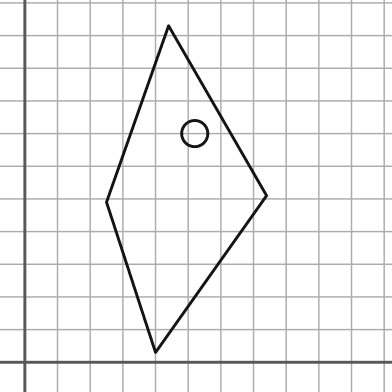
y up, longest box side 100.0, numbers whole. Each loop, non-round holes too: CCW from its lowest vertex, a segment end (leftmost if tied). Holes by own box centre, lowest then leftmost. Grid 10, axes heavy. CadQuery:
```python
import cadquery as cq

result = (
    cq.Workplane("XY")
    .moveTo(40.0, 3.0)
    .lineTo(74.0, 51.0)
    .lineTo(44.0, 103.0)
    .lineTo(25.0, 49.0)
    .close()
    .moveTo(52.0, 70.0)
    .circle(4.0)
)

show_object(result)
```